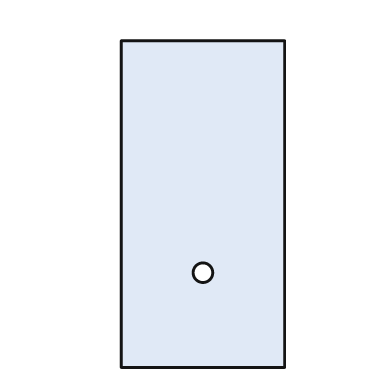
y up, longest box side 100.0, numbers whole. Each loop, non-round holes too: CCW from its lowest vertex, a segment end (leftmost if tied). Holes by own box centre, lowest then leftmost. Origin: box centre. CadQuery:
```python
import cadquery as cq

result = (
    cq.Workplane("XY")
    .moveTo(-25.0, -50.0)
    .lineTo(25.0, -50.0)
    .lineTo(25.0, 50.0)
    .lineTo(-25.0, 50.0)
    .close()
    .moveTo(0.0, -21.0)
    .circle(3.0)
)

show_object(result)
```